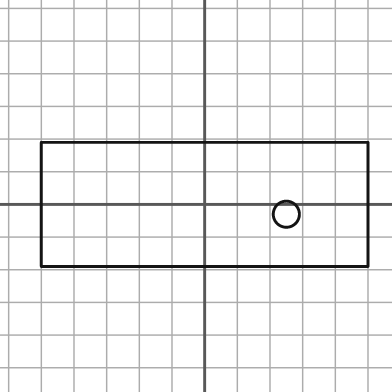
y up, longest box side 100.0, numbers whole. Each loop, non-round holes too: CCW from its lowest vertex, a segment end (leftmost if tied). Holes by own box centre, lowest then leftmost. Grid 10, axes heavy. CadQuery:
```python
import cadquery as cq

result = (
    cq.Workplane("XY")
    .moveTo(-50.0, -19.0)
    .lineTo(50.0, -19.0)
    .lineTo(50.0, 19.0)
    .lineTo(-50.0, 19.0)
    .close()
    .moveTo(25.0, -3.0)
    .circle(4.0)
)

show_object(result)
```